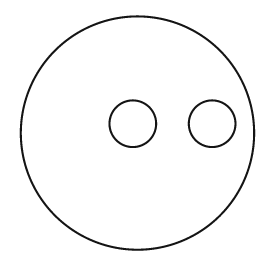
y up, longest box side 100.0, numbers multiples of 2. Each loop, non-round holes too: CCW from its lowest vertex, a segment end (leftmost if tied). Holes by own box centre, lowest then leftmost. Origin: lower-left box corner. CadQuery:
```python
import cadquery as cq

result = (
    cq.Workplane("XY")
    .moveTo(50.0, 50.0)
    .circle(50.0)
    .moveTo(48.0, 54.0)
    .circle(10.0)
    .moveTo(82.0, 54.0)
    .circle(10.0)
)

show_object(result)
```